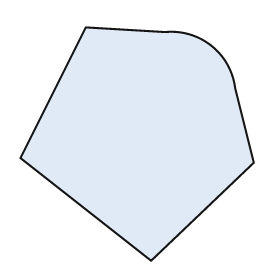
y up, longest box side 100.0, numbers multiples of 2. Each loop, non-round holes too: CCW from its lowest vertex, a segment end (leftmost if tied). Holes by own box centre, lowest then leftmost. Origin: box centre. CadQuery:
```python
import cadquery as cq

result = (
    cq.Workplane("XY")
    .moveTo(6.0, -50.0)
    .lineTo(50.0, -8.0)
    .lineTo(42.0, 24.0)
    .threePointArc((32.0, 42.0), (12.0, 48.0))
    .lineTo(-22.0, 50.0)
    .lineTo(-50.0, -6.0)
    .close()
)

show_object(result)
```